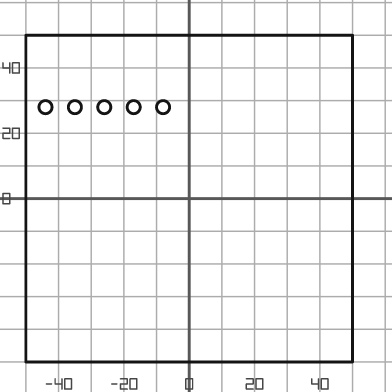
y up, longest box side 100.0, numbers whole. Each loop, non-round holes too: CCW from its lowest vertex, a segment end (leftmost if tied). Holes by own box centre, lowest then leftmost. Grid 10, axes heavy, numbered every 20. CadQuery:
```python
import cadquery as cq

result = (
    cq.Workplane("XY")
    .moveTo(-50.0, -50.0)
    .lineTo(50.0, -50.0)
    .lineTo(50.0, 50.0)
    .lineTo(-50.0, 50.0)
    .close()
    .moveTo(-44.0, 28.0)
    .circle(2.0)
    .moveTo(-35.0, 28.0)
    .circle(2.0)
    .moveTo(-26.0, 28.0)
    .circle(2.0)
    .moveTo(-17.0, 28.0)
    .circle(2.0)
    .moveTo(-8.0, 28.0)
    .circle(2.0)
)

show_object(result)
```